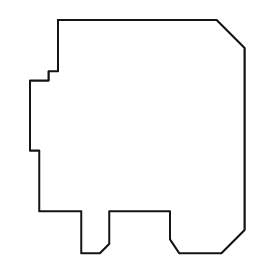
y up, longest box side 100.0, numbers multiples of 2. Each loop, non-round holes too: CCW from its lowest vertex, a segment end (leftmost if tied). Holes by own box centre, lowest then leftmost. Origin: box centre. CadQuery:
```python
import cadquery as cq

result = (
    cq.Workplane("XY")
    .moveTo(-24.0, -50.0)
    .lineTo(-16.0, -50.0)
    .lineTo(-12.0, -46.0)
    .lineTo(-12.0, -32.0)
    .lineTo(14.0, -32.0)
    .lineTo(14.0, -44.0)
    .lineTo(18.0, -50.0)
    .lineTo(36.0, -50.0)
    .lineTo(46.0, -40.0)
    .lineTo(46.0, 38.0)
    .lineTo(34.0, 50.0)
    .lineTo(-34.0, 50.0)
    .lineTo(-34.0, 28.0)
    .lineTo(-38.0, 28.0)
    .lineTo(-38.0, 24.0)
    .lineTo(-46.0, 24.0)
    .lineTo(-46.0, -6.0)
    .lineTo(-42.0, -6.0)
    .lineTo(-42.0, -32.0)
    .lineTo(-24.0, -32.0)
    .close()
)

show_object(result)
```